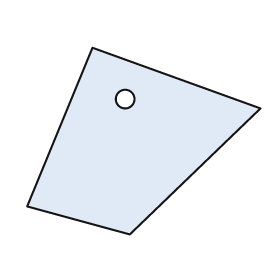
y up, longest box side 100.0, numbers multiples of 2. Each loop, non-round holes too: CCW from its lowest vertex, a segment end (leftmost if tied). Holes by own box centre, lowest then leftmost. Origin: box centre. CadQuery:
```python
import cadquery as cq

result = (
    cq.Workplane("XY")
    .moveTo(-6.0, -40.0)
    .lineTo(50.0, 14.0)
    .lineTo(-22.0, 40.0)
    .lineTo(-50.0, -28.0)
    .close()
    .moveTo(-8.0, 18.0)
    .circle(4.0)
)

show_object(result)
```